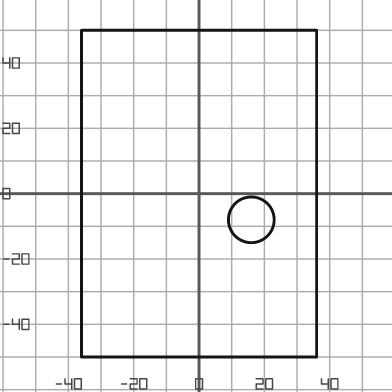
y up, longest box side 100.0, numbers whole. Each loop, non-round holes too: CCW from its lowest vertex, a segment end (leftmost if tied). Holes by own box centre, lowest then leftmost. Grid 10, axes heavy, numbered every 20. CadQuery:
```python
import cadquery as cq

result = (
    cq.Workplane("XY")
    .moveTo(-36.0, -50.0)
    .lineTo(36.0, -50.0)
    .lineTo(36.0, 50.0)
    .lineTo(-36.0, 50.0)
    .close()
    .moveTo(16.0, -8.0)
    .circle(7.0)
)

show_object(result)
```